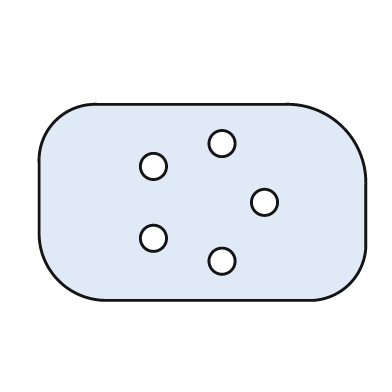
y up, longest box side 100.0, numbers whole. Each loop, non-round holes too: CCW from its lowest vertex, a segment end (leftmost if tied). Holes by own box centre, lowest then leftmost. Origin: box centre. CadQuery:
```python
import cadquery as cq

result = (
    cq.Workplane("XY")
    .moveTo(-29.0, -30.0)
    .lineTo(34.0, -30.0)
    .threePointArc((45.0, -25.0), (50.0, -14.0))
    .lineTo(50.0, 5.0)
    .threePointArc((43.0, 23.0), (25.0, 30.0))
    .lineTo(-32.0, 30.0)
    .threePointArc((-45.0, 25.0), (-50.0, 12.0))
    .lineTo(-50.0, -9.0)
    .threePointArc((-44.0, -24.0), (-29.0, -30.0))
    .close()
    .moveTo(6.0, -18.0)
    .circle(4.0)
    .moveTo(-15.0, -11.0)
    .circle(4.0)
    .moveTo(19.0, 0.0)
    .circle(4.0)
    .moveTo(-15.0, 11.0)
    .circle(4.0)
    .moveTo(6.0, 18.0)
    .circle(4.0)
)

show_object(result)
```